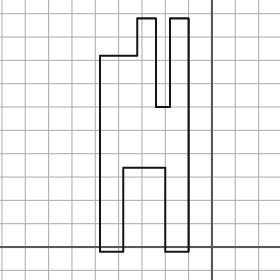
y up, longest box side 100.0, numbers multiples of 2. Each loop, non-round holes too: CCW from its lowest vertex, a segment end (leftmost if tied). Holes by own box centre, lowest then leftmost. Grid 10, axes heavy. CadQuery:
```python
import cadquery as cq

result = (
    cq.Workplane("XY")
    .moveTo(-48.0, -2.0)
    .lineTo(-38.0, -2.0)
    .lineTo(-38.0, 34.0)
    .lineTo(-20.0, 34.0)
    .lineTo(-20.0, -2.0)
    .lineTo(-10.0, -2.0)
    .lineTo(-10.0, 98.0)
    .lineTo(-18.0, 98.0)
    .lineTo(-18.0, 60.0)
    .lineTo(-24.0, 60.0)
    .lineTo(-24.0, 98.0)
    .lineTo(-32.0, 98.0)
    .lineTo(-32.0, 82.0)
    .lineTo(-48.0, 82.0)
    .close()
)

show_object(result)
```